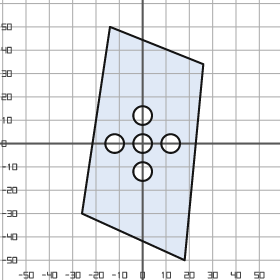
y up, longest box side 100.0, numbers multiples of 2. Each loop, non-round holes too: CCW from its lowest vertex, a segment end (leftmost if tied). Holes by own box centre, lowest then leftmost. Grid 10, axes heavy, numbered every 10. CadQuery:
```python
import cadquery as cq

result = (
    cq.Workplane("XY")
    .moveTo(18.0, -50.0)
    .lineTo(26.0, 34.0)
    .lineTo(-14.0, 50.0)
    .lineTo(-26.0, -30.0)
    .close()
    .moveTo(0.0, -12.0)
    .circle(4.0)
    .moveTo(-12.0, 0.0)
    .circle(4.0)
    .moveTo(0.0, 0.0)
    .circle(4.0)
    .moveTo(12.0, 0.0)
    .circle(4.0)
    .moveTo(0.0, 12.0)
    .circle(4.0)
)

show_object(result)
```